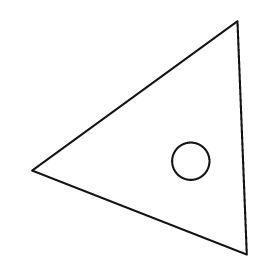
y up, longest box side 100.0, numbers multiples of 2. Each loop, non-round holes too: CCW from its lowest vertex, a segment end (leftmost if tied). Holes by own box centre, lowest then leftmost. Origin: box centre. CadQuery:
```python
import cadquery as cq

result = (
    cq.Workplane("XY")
    .moveTo(46.0, -50.0)
    .lineTo(42.0, 50.0)
    .lineTo(-46.0, -14.0)
    .close()
    .moveTo(22.0, -10.0)
    .circle(8.0)
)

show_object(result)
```